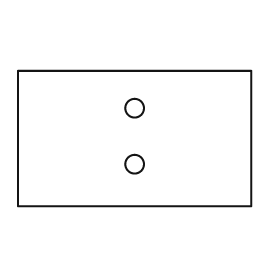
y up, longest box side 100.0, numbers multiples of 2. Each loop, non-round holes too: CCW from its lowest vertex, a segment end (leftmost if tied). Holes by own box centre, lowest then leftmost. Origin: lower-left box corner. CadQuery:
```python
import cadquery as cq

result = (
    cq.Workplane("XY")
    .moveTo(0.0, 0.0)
    .lineTo(100.0, 0.0)
    .lineTo(100.0, 58.0)
    .lineTo(0.0, 58.0)
    .close()
    .moveTo(50.0, 18.0)
    .circle(4.0)
    .moveTo(50.0, 42.0)
    .circle(4.0)
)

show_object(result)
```